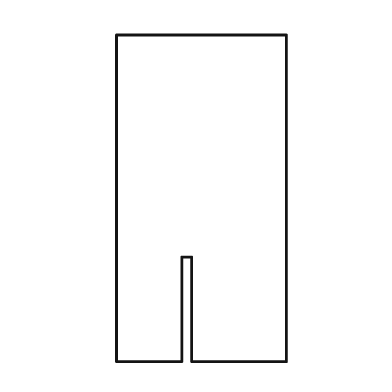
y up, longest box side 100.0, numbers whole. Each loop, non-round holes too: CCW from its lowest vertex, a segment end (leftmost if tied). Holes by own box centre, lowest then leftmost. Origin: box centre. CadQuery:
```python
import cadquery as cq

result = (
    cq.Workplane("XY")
    .moveTo(-26.0, -50.0)
    .lineTo(-6.0, -50.0)
    .lineTo(-6.0, -18.0)
    .lineTo(-3.0, -18.0)
    .lineTo(-3.0, -50.0)
    .lineTo(26.0, -50.0)
    .lineTo(26.0, 50.0)
    .lineTo(-26.0, 50.0)
    .close()
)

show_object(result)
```